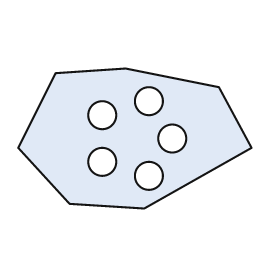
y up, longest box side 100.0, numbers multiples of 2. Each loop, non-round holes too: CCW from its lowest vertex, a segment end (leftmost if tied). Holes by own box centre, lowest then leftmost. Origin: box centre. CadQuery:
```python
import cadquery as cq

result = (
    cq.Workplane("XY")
    .moveTo(4.0, -30.0)
    .lineTo(50.0, -4.0)
    .lineTo(36.0, 22.0)
    .lineTo(-4.0, 30.0)
    .lineTo(-34.0, 28.0)
    .lineTo(-50.0, -4.0)
    .lineTo(-28.0, -28.0)
    .close()
    .moveTo(6.0, -16.0)
    .circle(6.0)
    .moveTo(-14.0, -10.0)
    .circle(6.0)
    .moveTo(16.0, 0.0)
    .circle(6.0)
    .moveTo(-14.0, 10.0)
    .circle(6.0)
    .moveTo(6.0, 16.0)
    .circle(6.0)
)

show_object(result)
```